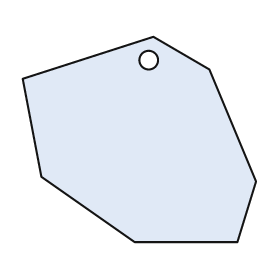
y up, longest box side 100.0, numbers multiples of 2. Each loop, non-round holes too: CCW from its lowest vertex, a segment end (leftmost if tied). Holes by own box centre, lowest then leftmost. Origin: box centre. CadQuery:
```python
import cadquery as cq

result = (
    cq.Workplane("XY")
    .moveTo(-2.0, -44.0)
    .lineTo(42.0, -44.0)
    .lineTo(50.0, -18.0)
    .lineTo(30.0, 30.0)
    .lineTo(6.0, 44.0)
    .lineTo(-50.0, 26.0)
    .lineTo(-42.0, -16.0)
    .close()
    .moveTo(4.0, 34.0)
    .circle(4.0)
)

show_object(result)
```